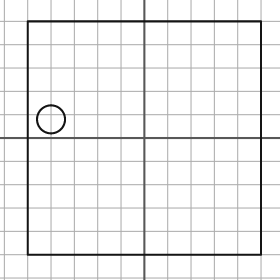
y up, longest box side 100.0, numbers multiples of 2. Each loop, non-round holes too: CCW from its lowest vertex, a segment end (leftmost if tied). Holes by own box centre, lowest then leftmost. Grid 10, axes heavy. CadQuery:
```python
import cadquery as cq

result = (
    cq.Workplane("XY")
    .moveTo(-50.0, -50.0)
    .lineTo(50.0, -50.0)
    .lineTo(50.0, 50.0)
    .lineTo(-50.0, 50.0)
    .close()
    .moveTo(-40.0, 8.0)
    .circle(6.0)
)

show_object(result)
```